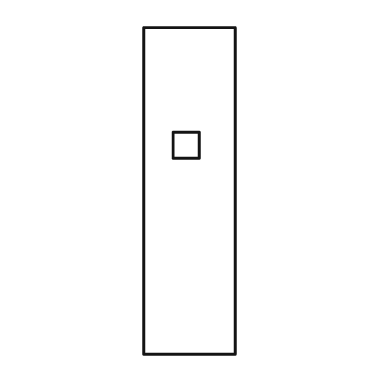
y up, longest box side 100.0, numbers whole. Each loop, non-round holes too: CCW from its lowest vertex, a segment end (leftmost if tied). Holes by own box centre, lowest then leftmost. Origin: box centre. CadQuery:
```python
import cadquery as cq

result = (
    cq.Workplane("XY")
    .moveTo(-14.0, -50.0)
    .lineTo(14.0, -50.0)
    .lineTo(14.0, 50.0)
    .lineTo(-14.0, 50.0)
    .close()
    .moveTo(-5.0, 10.0)
    .lineTo(3.0, 10.0)
    .lineTo(3.0, 18.0)
    .lineTo(-5.0, 18.0)
    .close()
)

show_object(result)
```